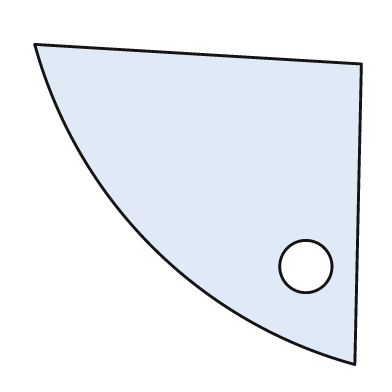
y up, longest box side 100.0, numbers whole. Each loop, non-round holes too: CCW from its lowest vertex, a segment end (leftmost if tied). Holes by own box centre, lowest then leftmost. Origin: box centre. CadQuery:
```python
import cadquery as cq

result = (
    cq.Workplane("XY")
    .moveTo(48.0, -49.0)
    .lineTo(50.0, 43.0)
    .lineTo(-50.0, 49.0)
    .threePointArc((-14.0, -13.0), (48.0, -49.0))
    .close()
    .moveTo(33.0, -19.0)
    .circle(8.0)
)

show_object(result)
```